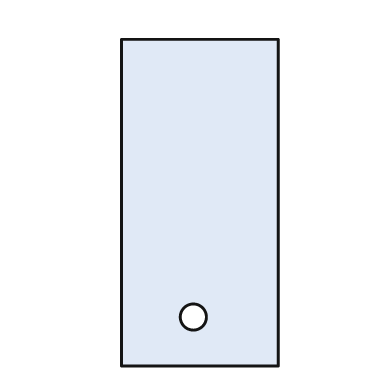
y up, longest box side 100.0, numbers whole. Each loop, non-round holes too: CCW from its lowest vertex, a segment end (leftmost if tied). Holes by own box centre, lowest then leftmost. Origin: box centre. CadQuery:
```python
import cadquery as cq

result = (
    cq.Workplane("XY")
    .moveTo(-24.0, -50.0)
    .lineTo(24.0, -50.0)
    .lineTo(24.0, 50.0)
    .lineTo(-24.0, 50.0)
    .close()
    .moveTo(-2.0, -35.0)
    .circle(4.0)
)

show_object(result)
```